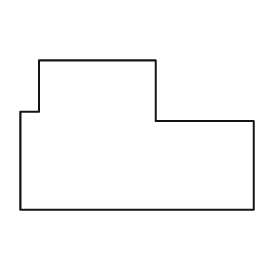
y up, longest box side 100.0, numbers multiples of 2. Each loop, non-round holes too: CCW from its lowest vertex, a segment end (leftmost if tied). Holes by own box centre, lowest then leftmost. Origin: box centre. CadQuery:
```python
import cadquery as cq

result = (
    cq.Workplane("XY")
    .moveTo(-50.0, -32.0)
    .lineTo(50.0, -32.0)
    .lineTo(50.0, 6.0)
    .lineTo(8.0, 6.0)
    .lineTo(8.0, 32.0)
    .lineTo(-42.0, 32.0)
    .lineTo(-42.0, 10.0)
    .lineTo(-50.0, 10.0)
    .close()
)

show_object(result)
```